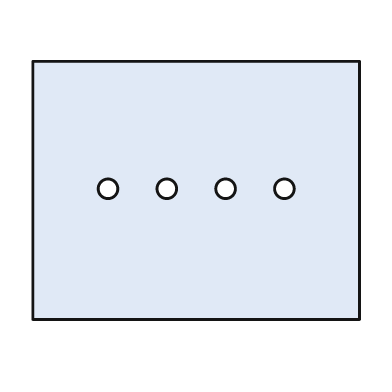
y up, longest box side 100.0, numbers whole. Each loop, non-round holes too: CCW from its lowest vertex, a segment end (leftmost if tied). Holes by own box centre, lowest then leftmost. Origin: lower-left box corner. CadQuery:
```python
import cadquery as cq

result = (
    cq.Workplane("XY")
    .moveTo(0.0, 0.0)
    .lineTo(100.0, 0.0)
    .lineTo(100.0, 79.0)
    .lineTo(0.0, 79.0)
    .close()
    .moveTo(23.0, 40.0)
    .circle(3.0)
    .moveTo(41.0, 40.0)
    .circle(3.0)
    .moveTo(59.0, 40.0)
    .circle(3.0)
    .moveTo(77.0, 40.0)
    .circle(3.0)
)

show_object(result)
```